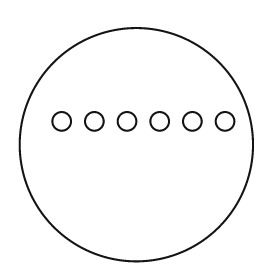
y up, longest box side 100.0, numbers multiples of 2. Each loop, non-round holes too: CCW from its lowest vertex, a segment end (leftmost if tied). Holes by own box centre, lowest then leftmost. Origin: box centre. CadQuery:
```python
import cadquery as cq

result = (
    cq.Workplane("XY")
    .moveTo(0.0, 0.0)
    .circle(50.0)
    .moveTo(-32.0, 10.0)
    .circle(4.0)
    .moveTo(-18.0, 10.0)
    .circle(4.0)
    .moveTo(-4.0, 10.0)
    .circle(4.0)
    .moveTo(10.0, 10.0)
    .circle(4.0)
    .moveTo(24.0, 10.0)
    .circle(4.0)
    .moveTo(38.0, 10.0)
    .circle(4.0)
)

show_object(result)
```